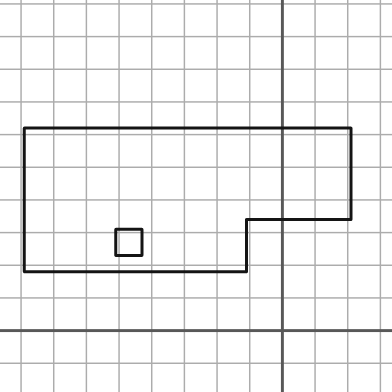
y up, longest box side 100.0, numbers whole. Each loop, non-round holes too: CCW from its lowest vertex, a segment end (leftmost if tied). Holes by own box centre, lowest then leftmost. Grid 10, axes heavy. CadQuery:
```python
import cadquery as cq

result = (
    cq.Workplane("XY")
    .moveTo(-79.0, 18.0)
    .lineTo(-11.0, 18.0)
    .lineTo(-11.0, 34.0)
    .lineTo(21.0, 34.0)
    .lineTo(21.0, 62.0)
    .lineTo(-79.0, 62.0)
    .close()
    .moveTo(-51.0, 23.0)
    .lineTo(-43.0, 23.0)
    .lineTo(-43.0, 31.0)
    .lineTo(-51.0, 31.0)
    .close()
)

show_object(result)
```